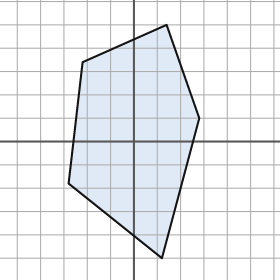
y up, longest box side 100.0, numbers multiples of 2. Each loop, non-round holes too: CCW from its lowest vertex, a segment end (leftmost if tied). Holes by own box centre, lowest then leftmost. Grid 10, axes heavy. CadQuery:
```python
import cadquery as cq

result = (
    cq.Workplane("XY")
    .moveTo(12.0, -50.0)
    .lineTo(28.0, 10.0)
    .lineTo(14.0, 50.0)
    .lineTo(-22.0, 34.0)
    .lineTo(-28.0, -18.0)
    .close()
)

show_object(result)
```